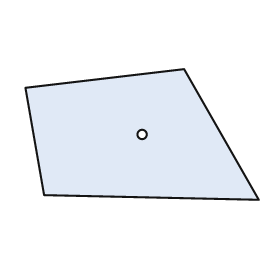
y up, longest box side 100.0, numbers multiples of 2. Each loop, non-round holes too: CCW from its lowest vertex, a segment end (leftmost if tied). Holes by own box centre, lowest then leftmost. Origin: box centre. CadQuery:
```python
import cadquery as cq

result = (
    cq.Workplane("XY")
    .moveTo(50.0, -28.0)
    .lineTo(18.0, 28.0)
    .lineTo(-50.0, 20.0)
    .lineTo(-42.0, -26.0)
    .close()
    .moveTo(0.0, 0.0)
    .circle(2.0)
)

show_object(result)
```